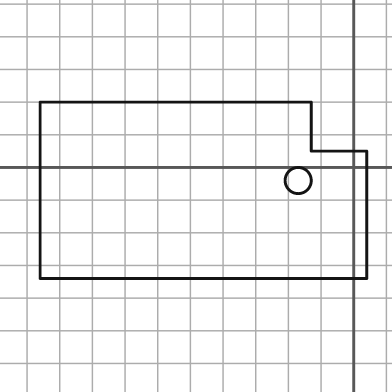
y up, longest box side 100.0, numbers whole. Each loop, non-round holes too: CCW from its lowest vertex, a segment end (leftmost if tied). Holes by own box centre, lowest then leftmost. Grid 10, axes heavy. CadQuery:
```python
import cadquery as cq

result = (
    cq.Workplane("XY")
    .moveTo(-96.0, -34.0)
    .lineTo(4.0, -34.0)
    .lineTo(4.0, 5.0)
    .lineTo(-13.0, 5.0)
    .lineTo(-13.0, 20.0)
    .lineTo(-96.0, 20.0)
    .close()
    .moveTo(-17.0, -4.0)
    .circle(4.0)
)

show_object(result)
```